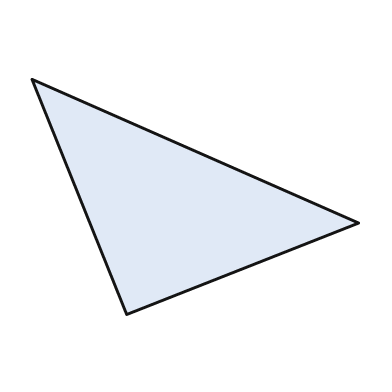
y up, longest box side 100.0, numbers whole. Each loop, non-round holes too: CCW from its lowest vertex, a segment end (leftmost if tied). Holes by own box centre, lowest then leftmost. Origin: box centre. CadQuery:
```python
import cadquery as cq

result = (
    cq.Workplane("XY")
    .moveTo(-21.0, -36.0)
    .lineTo(50.0, -8.0)
    .lineTo(-50.0, 36.0)
    .close()
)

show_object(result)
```